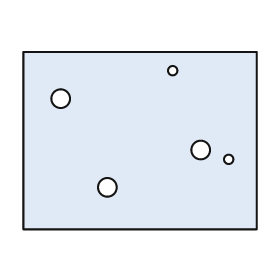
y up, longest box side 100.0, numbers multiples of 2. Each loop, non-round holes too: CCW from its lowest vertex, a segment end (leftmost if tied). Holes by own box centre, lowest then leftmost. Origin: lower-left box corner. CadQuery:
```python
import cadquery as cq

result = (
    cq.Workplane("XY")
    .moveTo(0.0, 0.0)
    .lineTo(100.0, 0.0)
    .lineTo(100.0, 76.0)
    .lineTo(0.0, 76.0)
    .close()
    .moveTo(36.0, 18.0)
    .circle(4.0)
    .moveTo(88.0, 30.0)
    .circle(2.0)
    .moveTo(76.0, 34.0)
    .circle(4.0)
    .moveTo(16.0, 56.0)
    .circle(4.0)
    .moveTo(64.0, 68.0)
    .circle(2.0)
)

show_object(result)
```